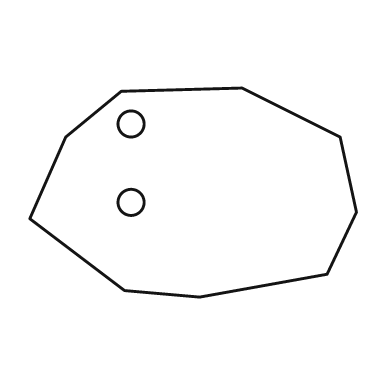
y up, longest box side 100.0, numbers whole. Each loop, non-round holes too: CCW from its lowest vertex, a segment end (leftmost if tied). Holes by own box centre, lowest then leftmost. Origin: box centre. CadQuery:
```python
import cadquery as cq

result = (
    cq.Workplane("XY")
    .moveTo(2.0, -32.0)
    .lineTo(41.0, -25.0)
    .lineTo(50.0, -6.0)
    .lineTo(45.0, 17.0)
    .lineTo(15.0, 32.0)
    .lineTo(-22.0, 31.0)
    .lineTo(-39.0, 17.0)
    .lineTo(-50.0, -8.0)
    .lineTo(-21.0, -30.0)
    .close()
    .moveTo(-19.0, -3.0)
    .circle(4.0)
    .moveTo(-19.0, 21.0)
    .circle(4.0)
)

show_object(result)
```